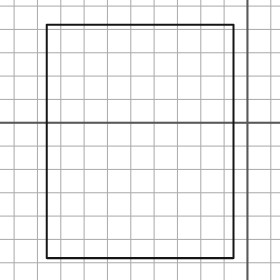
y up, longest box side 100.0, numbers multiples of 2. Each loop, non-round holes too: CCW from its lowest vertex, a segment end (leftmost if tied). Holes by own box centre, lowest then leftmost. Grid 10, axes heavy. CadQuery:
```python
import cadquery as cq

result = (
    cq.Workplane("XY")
    .moveTo(-86.0, -58.0)
    .lineTo(-6.0, -58.0)
    .lineTo(-6.0, 42.0)
    .lineTo(-86.0, 42.0)
    .close()
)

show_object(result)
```